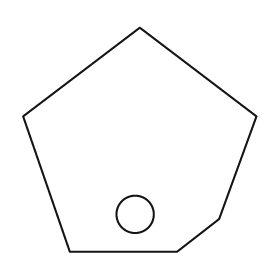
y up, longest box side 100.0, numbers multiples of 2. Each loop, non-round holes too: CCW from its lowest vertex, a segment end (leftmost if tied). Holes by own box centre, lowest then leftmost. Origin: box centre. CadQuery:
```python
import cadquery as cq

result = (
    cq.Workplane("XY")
    .moveTo(-30.0, -48.0)
    .lineTo(16.0, -48.0)
    .lineTo(34.0, -34.0)
    .lineTo(50.0, 10.0)
    .lineTo(0.0, 48.0)
    .lineTo(-50.0, 10.0)
    .close()
    .moveTo(-2.0, -32.0)
    .circle(8.0)
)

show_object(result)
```